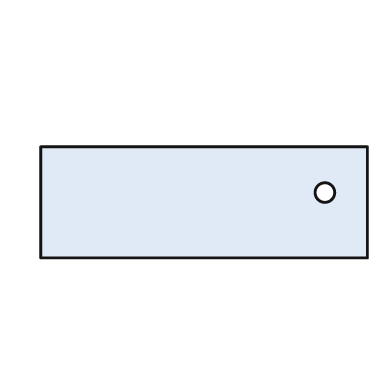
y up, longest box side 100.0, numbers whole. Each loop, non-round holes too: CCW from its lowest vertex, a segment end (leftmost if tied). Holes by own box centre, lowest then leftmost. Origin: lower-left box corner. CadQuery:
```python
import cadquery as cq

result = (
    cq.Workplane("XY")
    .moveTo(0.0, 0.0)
    .lineTo(100.0, 0.0)
    .lineTo(100.0, 34.0)
    .lineTo(0.0, 34.0)
    .close()
    .moveTo(87.0, 20.0)
    .circle(3.0)
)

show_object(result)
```